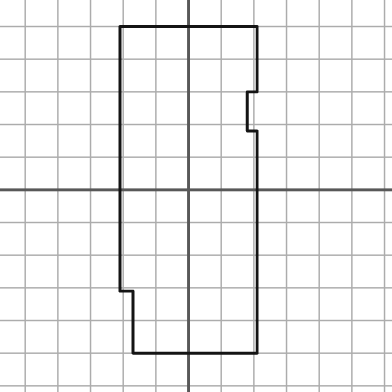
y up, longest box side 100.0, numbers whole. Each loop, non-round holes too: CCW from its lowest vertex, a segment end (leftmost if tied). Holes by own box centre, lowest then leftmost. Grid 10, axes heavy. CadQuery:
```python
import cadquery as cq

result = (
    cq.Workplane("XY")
    .moveTo(-17.0, -50.0)
    .lineTo(21.0, -50.0)
    .lineTo(21.0, 18.0)
    .lineTo(18.0, 18.0)
    .lineTo(18.0, 30.0)
    .lineTo(21.0, 30.0)
    .lineTo(21.0, 50.0)
    .lineTo(-21.0, 50.0)
    .lineTo(-21.0, -31.0)
    .lineTo(-17.0, -31.0)
    .close()
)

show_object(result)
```